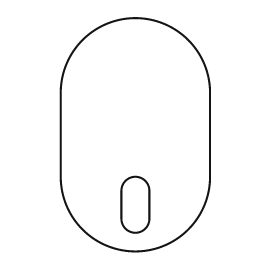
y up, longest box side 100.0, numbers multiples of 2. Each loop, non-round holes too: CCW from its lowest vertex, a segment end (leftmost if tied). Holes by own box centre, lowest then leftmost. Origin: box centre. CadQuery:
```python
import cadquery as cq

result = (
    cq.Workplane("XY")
    .moveTo(-32.0, -18.0)
    .threePointArc((0.0, -50.0), (32.0, -18.0))
    .lineTo(32.0, 18.0)
    .threePointArc((0.0, 50.0), (-32.0, 18.0))
    .close()
    .moveTo(-6.0, -36.0)
    .threePointArc((0.0, -42.0), (6.0, -36.0))
    .lineTo(6.0, -24.0)
    .threePointArc((0.0, -18.0), (-6.0, -24.0))
    .close()
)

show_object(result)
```